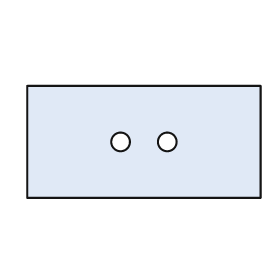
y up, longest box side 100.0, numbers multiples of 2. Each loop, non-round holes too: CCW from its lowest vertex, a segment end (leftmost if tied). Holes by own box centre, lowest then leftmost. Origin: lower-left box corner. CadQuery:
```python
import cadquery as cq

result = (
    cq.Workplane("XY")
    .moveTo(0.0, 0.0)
    .lineTo(100.0, 0.0)
    .lineTo(100.0, 48.0)
    .lineTo(0.0, 48.0)
    .close()
    .moveTo(40.0, 24.0)
    .circle(4.0)
    .moveTo(60.0, 24.0)
    .circle(4.0)
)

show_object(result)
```